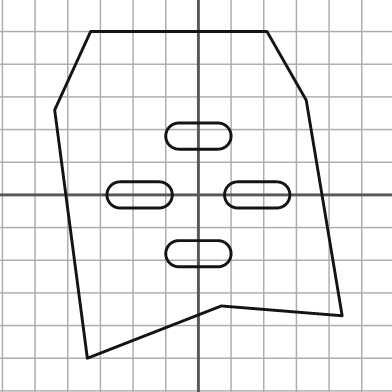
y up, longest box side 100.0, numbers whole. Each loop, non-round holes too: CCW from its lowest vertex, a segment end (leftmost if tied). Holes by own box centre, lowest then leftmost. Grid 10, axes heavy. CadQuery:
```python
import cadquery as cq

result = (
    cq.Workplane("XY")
    .moveTo(-34.0, -50.0)
    .lineTo(7.0, -34.0)
    .lineTo(44.0, -37.0)
    .lineTo(33.0, 29.0)
    .lineTo(21.0, 50.0)
    .lineTo(-33.0, 50.0)
    .lineTo(-44.0, 26.0)
    .close()
    .moveTo(-6.0, -22.0)
    .lineTo(6.0, -22.0)
    .threePointArc((10.0, -18.0), (6.0, -14.0))
    .lineTo(-6.0, -14.0)
    .threePointArc((-10.0, -18.0), (-6.0, -22.0))
    .close()
    .moveTo(-24.0, -4.0)
    .lineTo(-12.0, -4.0)
    .threePointArc((-8.0, 0.0), (-12.0, 4.0))
    .lineTo(-24.0, 4.0)
    .threePointArc((-28.0, 0.0), (-24.0, -4.0))
    .close()
    .moveTo(12.0, -4.0)
    .lineTo(24.0, -4.0)
    .threePointArc((28.0, 0.0), (24.0, 4.0))
    .lineTo(12.0, 4.0)
    .threePointArc((8.0, 0.0), (12.0, -4.0))
    .close()
    .moveTo(-6.0, 14.0)
    .lineTo(6.0, 14.0)
    .threePointArc((10.0, 18.0), (6.0, 22.0))
    .lineTo(-6.0, 22.0)
    .threePointArc((-10.0, 18.0), (-6.0, 14.0))
    .close()
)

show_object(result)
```